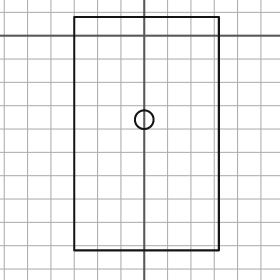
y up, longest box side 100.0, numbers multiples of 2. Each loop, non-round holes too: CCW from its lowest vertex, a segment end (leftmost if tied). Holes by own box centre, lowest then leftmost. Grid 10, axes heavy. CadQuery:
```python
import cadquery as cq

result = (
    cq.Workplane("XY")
    .moveTo(-30.0, -92.0)
    .lineTo(32.0, -92.0)
    .lineTo(32.0, 8.0)
    .lineTo(-30.0, 8.0)
    .close()
    .moveTo(0.0, -36.0)
    .circle(4.0)
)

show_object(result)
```